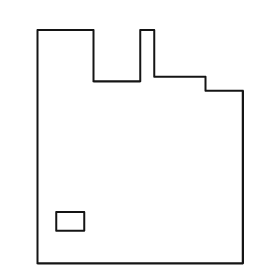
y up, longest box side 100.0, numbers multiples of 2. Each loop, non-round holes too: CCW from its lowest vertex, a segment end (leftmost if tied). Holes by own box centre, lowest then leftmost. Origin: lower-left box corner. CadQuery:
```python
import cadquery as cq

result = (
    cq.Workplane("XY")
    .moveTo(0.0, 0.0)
    .lineTo(88.0, 0.0)
    .lineTo(88.0, 74.0)
    .lineTo(72.0, 74.0)
    .lineTo(72.0, 80.0)
    .lineTo(50.0, 80.0)
    .lineTo(50.0, 100.0)
    .lineTo(44.0, 100.0)
    .lineTo(44.0, 78.0)
    .lineTo(24.0, 78.0)
    .lineTo(24.0, 100.0)
    .lineTo(0.0, 100.0)
    .close()
    .moveTo(8.0, 14.0)
    .lineTo(20.0, 14.0)
    .lineTo(20.0, 22.0)
    .lineTo(8.0, 22.0)
    .close()
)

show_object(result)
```